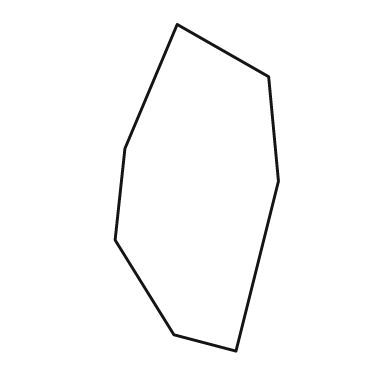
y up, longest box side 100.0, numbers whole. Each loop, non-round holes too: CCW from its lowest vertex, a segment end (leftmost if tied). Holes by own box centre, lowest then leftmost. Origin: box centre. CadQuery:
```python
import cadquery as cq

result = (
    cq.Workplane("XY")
    .moveTo(12.0, -50.0)
    .lineTo(25.0, 2.0)
    .lineTo(22.0, 34.0)
    .lineTo(-6.0, 50.0)
    .lineTo(-22.0, 12.0)
    .lineTo(-25.0, -16.0)
    .lineTo(-7.0, -45.0)
    .close()
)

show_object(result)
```